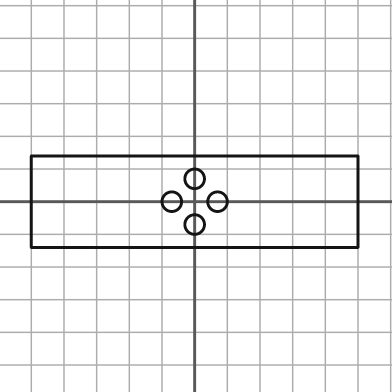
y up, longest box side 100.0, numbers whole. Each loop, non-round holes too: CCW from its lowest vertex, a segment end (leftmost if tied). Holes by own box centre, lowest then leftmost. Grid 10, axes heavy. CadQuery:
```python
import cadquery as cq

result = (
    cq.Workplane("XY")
    .moveTo(-50.0, -14.0)
    .lineTo(50.0, -14.0)
    .lineTo(50.0, 14.0)
    .lineTo(-50.0, 14.0)
    .close()
    .moveTo(0.0, -7.0)
    .circle(3.0)
    .moveTo(-7.0, 0.0)
    .circle(3.0)
    .moveTo(7.0, 0.0)
    .circle(3.0)
    .moveTo(0.0, 7.0)
    .circle(3.0)
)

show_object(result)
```